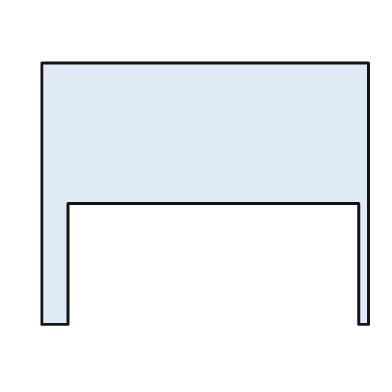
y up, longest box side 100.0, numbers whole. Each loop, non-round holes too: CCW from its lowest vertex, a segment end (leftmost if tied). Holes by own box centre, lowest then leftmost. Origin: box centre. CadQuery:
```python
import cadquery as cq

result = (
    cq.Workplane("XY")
    .moveTo(-50.0, -40.0)
    .lineTo(-42.0, -40.0)
    .lineTo(-42.0, -3.0)
    .lineTo(47.0, -3.0)
    .lineTo(47.0, -40.0)
    .lineTo(50.0, -40.0)
    .lineTo(50.0, 40.0)
    .lineTo(-50.0, 40.0)
    .close()
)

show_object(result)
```